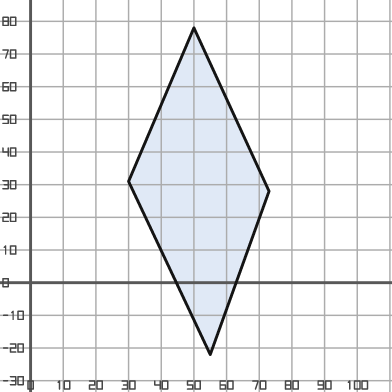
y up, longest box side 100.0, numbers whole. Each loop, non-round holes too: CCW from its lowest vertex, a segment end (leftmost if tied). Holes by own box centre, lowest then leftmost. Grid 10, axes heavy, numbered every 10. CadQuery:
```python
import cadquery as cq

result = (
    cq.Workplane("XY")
    .moveTo(55.0, -22.0)
    .lineTo(73.0, 28.0)
    .lineTo(50.0, 78.0)
    .lineTo(30.0, 31.0)
    .close()
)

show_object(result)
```